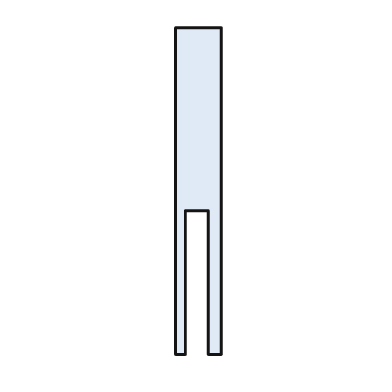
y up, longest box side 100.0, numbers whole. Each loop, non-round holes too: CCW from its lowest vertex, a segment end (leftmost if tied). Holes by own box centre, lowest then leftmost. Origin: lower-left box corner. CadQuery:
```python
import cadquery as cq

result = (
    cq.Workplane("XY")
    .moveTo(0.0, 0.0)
    .lineTo(3.0, 0.0)
    .lineTo(3.0, 44.0)
    .lineTo(10.0, 44.0)
    .lineTo(10.0, 0.0)
    .lineTo(14.0, 0.0)
    .lineTo(14.0, 100.0)
    .lineTo(0.0, 100.0)
    .close()
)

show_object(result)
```